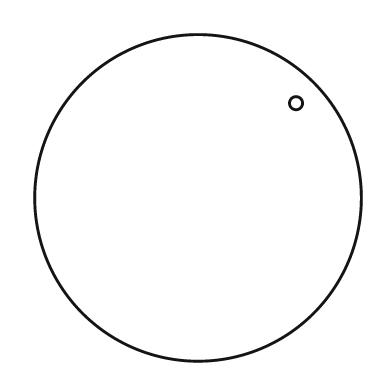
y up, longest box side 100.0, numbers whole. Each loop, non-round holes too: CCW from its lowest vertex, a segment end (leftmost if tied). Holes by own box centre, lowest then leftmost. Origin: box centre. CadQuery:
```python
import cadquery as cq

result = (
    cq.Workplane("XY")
    .moveTo(0.0, 0.0)
    .circle(50.0)
    .moveTo(30.0, 29.0)
    .circle(2.0)
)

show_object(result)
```